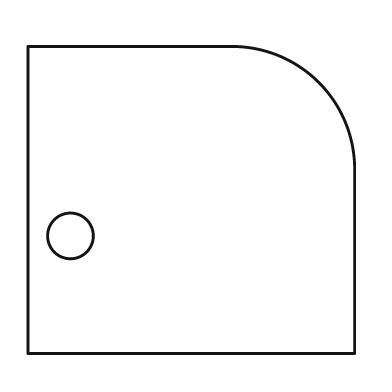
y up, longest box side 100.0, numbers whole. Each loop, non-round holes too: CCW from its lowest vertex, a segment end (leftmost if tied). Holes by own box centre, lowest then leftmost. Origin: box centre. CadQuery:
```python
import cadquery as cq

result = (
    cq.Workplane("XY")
    .moveTo(-50.0, -47.0)
    .lineTo(50.0, -47.0)
    .lineTo(50.0, 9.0)
    .threePointArc((39.0, 36.0), (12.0, 47.0))
    .lineTo(-50.0, 47.0)
    .close()
    .moveTo(-37.0, -11.0)
    .circle(7.0)
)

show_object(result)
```